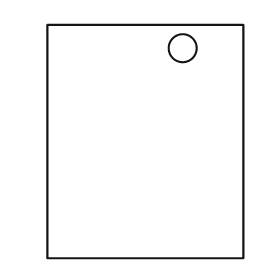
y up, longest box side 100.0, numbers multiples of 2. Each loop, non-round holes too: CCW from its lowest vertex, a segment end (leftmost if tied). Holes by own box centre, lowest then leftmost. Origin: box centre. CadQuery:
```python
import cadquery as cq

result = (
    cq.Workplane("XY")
    .moveTo(-42.0, -50.0)
    .lineTo(42.0, -50.0)
    .lineTo(42.0, 50.0)
    .lineTo(-42.0, 50.0)
    .close()
    .moveTo(16.0, 40.0)
    .circle(6.0)
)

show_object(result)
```